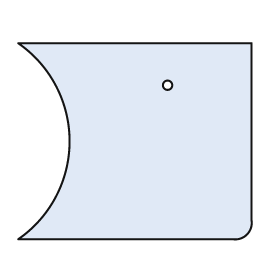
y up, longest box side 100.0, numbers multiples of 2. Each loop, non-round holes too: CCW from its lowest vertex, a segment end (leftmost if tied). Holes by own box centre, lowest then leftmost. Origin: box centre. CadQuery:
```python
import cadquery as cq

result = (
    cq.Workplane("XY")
    .moveTo(-50.0, -42.0)
    .lineTo(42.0, -42.0)
    .threePointArc((48.0, -40.0), (50.0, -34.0))
    .lineTo(50.0, 42.0)
    .lineTo(-50.0, 42.0)
    .threePointArc((-28.0, 0.0), (-50.0, -42.0))
    .close()
    .moveTo(14.0, 24.0)
    .circle(2.0)
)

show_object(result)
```